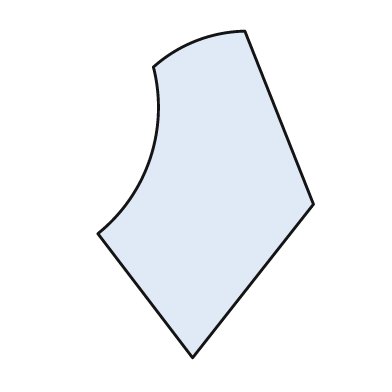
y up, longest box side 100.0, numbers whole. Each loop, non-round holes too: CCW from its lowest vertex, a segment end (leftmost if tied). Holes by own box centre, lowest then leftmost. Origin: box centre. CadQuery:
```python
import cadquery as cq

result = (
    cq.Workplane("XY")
    .moveTo(-4.0, -50.0)
    .lineTo(33.0, -3.0)
    .lineTo(12.0, 50.0)
    .threePointArc((-3.0, 47.0), (-16.0, 39.0))
    .threePointArc((-17.0, 11.0), (-33.0, -12.0))
    .close()
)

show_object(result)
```